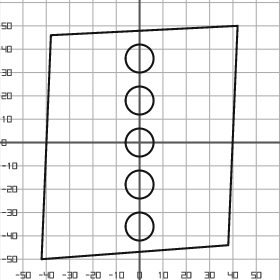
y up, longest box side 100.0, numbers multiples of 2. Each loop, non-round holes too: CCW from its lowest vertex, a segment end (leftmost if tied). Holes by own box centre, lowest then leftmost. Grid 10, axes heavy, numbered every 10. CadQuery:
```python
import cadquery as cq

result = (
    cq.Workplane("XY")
    .moveTo(-42.0, -50.0)
    .lineTo(38.0, -44.0)
    .lineTo(42.0, 50.0)
    .lineTo(-38.0, 46.0)
    .close()
    .moveTo(0.0, -36.0)
    .circle(6.0)
    .moveTo(0.0, -18.0)
    .circle(6.0)
    .moveTo(0.0, 0.0)
    .circle(6.0)
    .moveTo(0.0, 18.0)
    .circle(6.0)
    .moveTo(0.0, 36.0)
    .circle(6.0)
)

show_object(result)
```